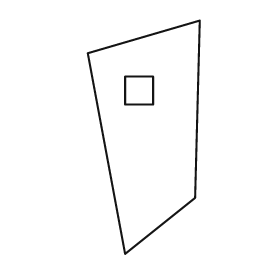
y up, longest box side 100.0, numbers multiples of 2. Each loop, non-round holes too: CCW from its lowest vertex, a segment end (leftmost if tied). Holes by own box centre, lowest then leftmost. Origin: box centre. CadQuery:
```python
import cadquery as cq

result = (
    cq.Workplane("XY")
    .moveTo(-8.0, -50.0)
    .lineTo(22.0, -26.0)
    .lineTo(24.0, 50.0)
    .lineTo(-24.0, 36.0)
    .close()
    .moveTo(-8.0, 14.0)
    .lineTo(4.0, 14.0)
    .lineTo(4.0, 26.0)
    .lineTo(-8.0, 26.0)
    .close()
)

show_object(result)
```